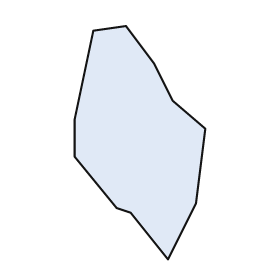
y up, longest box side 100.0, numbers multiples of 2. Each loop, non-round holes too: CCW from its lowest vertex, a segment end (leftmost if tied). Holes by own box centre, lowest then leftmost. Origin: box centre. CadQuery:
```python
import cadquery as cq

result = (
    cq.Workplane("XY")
    .moveTo(12.0, -50.0)
    .lineTo(24.0, -26.0)
    .lineTo(28.0, 6.0)
    .lineTo(14.0, 18.0)
    .lineTo(6.0, 34.0)
    .lineTo(-6.0, 50.0)
    .lineTo(-20.0, 48.0)
    .lineTo(-28.0, 10.0)
    .lineTo(-28.0, -6.0)
    .lineTo(-10.0, -28.0)
    .lineTo(-4.0, -30.0)
    .close()
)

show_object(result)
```